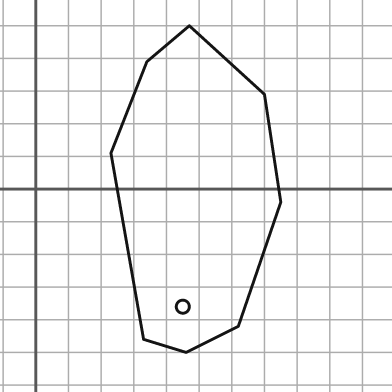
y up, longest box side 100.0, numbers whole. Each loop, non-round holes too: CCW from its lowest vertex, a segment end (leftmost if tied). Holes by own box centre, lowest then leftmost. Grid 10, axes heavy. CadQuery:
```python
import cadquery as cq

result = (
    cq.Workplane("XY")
    .moveTo(46.0, -50.0)
    .lineTo(62.0, -42.0)
    .lineTo(75.0, -4.0)
    .lineTo(70.0, 29.0)
    .lineTo(47.0, 50.0)
    .lineTo(34.0, 39.0)
    .lineTo(23.0, 11.0)
    .lineTo(33.0, -46.0)
    .close()
    .moveTo(45.0, -36.0)
    .circle(2.0)
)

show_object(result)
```